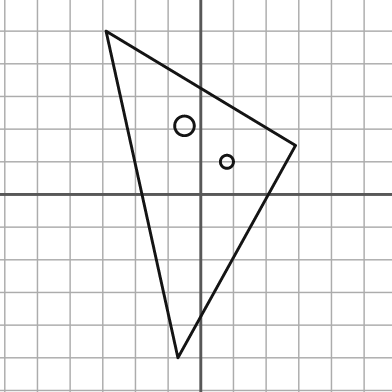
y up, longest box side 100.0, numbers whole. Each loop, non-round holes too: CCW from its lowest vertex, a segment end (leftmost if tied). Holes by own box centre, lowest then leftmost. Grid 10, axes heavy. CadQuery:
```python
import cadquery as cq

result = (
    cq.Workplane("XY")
    .moveTo(-7.0, -50.0)
    .lineTo(29.0, 15.0)
    .lineTo(-29.0, 50.0)
    .close()
    .moveTo(8.0, 10.0)
    .circle(2.0)
    .moveTo(-5.0, 21.0)
    .circle(3.0)
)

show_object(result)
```